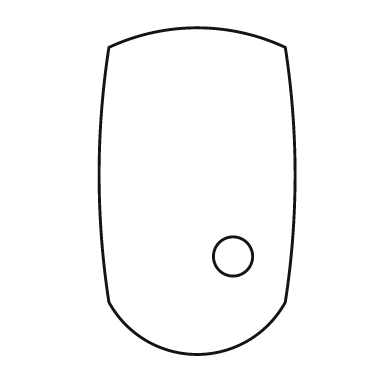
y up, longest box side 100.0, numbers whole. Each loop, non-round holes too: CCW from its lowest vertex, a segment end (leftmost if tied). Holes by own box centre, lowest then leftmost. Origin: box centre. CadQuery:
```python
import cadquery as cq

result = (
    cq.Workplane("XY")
    .moveTo(-27.0, -34.0)
    .threePointArc((0.0, -50.0), (27.0, -34.0))
    .threePointArc((30.0, 5.0), (27.0, 44.0))
    .threePointArc((0.0, 50.0), (-27.0, 44.0))
    .threePointArc((-30.0, 5.0), (-27.0, -34.0))
    .close()
    .moveTo(11.0, -20.0)
    .circle(6.0)
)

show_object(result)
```